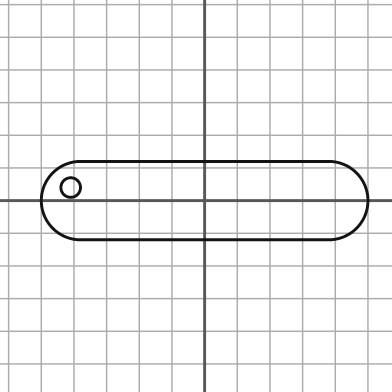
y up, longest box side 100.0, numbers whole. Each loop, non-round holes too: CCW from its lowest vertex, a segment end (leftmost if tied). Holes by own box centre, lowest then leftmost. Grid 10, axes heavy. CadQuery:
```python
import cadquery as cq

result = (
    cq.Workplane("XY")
    .moveTo(-38.0, -12.0)
    .lineTo(38.0, -12.0)
    .threePointArc((50.0, 0.0), (38.0, 12.0))
    .lineTo(-38.0, 12.0)
    .threePointArc((-50.0, 0.0), (-38.0, -12.0))
    .close()
    .moveTo(-41.0, 4.0)
    .circle(3.0)
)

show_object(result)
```